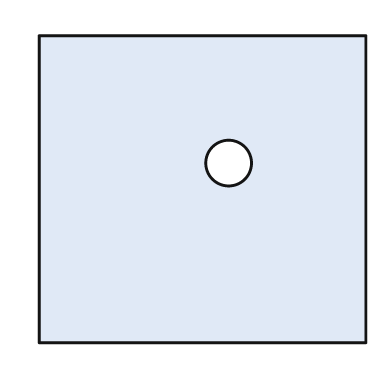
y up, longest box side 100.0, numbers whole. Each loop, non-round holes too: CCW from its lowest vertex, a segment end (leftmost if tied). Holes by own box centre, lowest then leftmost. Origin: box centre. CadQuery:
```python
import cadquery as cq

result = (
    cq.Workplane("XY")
    .moveTo(-50.0, -47.0)
    .lineTo(50.0, -47.0)
    .lineTo(50.0, 47.0)
    .lineTo(-50.0, 47.0)
    .close()
    .moveTo(8.0, 8.0)
    .circle(7.0)
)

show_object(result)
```